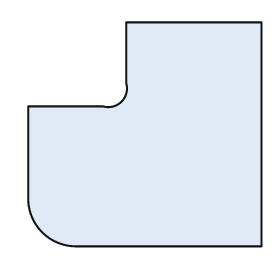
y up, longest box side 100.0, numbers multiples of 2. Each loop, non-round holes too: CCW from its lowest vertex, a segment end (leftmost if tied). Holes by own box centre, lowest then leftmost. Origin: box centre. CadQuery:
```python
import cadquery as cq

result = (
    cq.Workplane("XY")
    .moveTo(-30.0, -48.0)
    .lineTo(50.0, -48.0)
    .lineTo(50.0, 48.0)
    .lineTo(-8.0, 48.0)
    .lineTo(-8.0, 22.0)
    .threePointArc((-10.0, 14.0), (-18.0, 12.0))
    .lineTo(-50.0, 12.0)
    .lineTo(-50.0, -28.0)
    .threePointArc((-44.0, -42.0), (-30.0, -48.0))
    .close()
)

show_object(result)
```